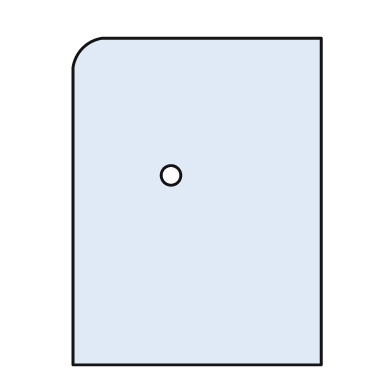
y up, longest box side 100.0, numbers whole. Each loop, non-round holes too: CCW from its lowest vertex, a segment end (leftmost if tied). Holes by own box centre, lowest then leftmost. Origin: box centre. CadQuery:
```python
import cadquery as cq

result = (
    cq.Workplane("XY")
    .moveTo(-38.0, -50.0)
    .lineTo(38.0, -50.0)
    .lineTo(38.0, 50.0)
    .lineTo(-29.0, 50.0)
    .threePointArc((-35.0, 47.0), (-38.0, 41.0))
    .close()
    .moveTo(-8.0, 8.0)
    .circle(3.0)
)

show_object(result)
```